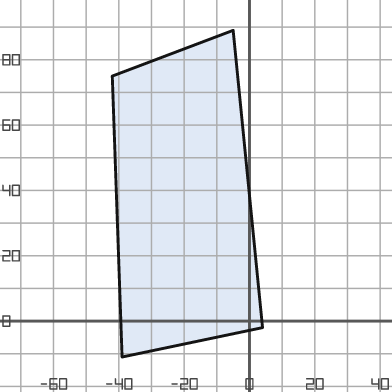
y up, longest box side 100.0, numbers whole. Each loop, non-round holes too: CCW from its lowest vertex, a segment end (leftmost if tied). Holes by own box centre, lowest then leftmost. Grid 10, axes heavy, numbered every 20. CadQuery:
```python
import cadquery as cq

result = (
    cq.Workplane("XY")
    .moveTo(-39.0, -11.0)
    .lineTo(4.0, -2.0)
    .lineTo(-5.0, 89.0)
    .lineTo(-42.0, 75.0)
    .close()
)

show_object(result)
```